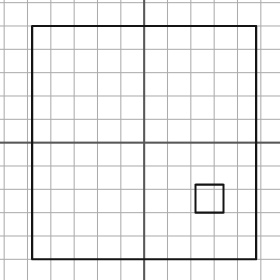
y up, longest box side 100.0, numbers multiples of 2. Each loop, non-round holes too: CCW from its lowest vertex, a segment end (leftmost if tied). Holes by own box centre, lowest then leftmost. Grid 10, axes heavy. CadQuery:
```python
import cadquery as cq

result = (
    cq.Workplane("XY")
    .moveTo(-48.0, -50.0)
    .lineTo(48.0, -50.0)
    .lineTo(48.0, 50.0)
    .lineTo(-48.0, 50.0)
    .close()
    .moveTo(22.0, -30.0)
    .lineTo(34.0, -30.0)
    .lineTo(34.0, -18.0)
    .lineTo(22.0, -18.0)
    .close()
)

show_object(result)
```